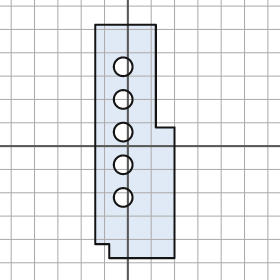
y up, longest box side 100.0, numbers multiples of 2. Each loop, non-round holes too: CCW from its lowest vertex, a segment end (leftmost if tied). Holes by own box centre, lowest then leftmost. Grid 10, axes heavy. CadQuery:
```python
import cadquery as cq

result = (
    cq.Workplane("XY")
    .moveTo(-8.0, -48.0)
    .lineTo(20.0, -48.0)
    .lineTo(20.0, 8.0)
    .lineTo(12.0, 8.0)
    .lineTo(12.0, 52.0)
    .lineTo(-14.0, 52.0)
    .lineTo(-14.0, -42.0)
    .lineTo(-8.0, -42.0)
    .close()
    .moveTo(-2.0, -22.0)
    .circle(4.0)
    .moveTo(-2.0, -8.0)
    .circle(4.0)
    .moveTo(-2.0, 6.0)
    .circle(4.0)
    .moveTo(-2.0, 20.0)
    .circle(4.0)
    .moveTo(-2.0, 34.0)
    .circle(4.0)
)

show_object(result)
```